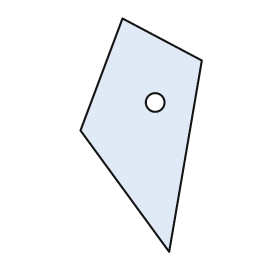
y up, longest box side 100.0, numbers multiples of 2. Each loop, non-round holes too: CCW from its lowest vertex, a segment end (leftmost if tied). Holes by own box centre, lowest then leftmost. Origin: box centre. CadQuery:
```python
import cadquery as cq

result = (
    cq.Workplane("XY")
    .moveTo(12.0, -50.0)
    .lineTo(26.0, 32.0)
    .lineTo(-8.0, 50.0)
    .lineTo(-26.0, 2.0)
    .close()
    .moveTo(6.0, 14.0)
    .circle(4.0)
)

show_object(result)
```